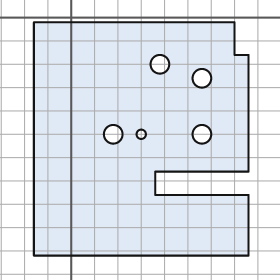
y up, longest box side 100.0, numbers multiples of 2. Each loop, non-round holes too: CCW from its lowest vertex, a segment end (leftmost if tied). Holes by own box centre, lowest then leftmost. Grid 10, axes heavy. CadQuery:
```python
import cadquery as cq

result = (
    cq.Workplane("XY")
    .moveTo(-16.0, -102.0)
    .lineTo(76.0, -102.0)
    .lineTo(76.0, -76.0)
    .lineTo(36.0, -76.0)
    .lineTo(36.0, -66.0)
    .lineTo(76.0, -66.0)
    .lineTo(76.0, -16.0)
    .lineTo(70.0, -16.0)
    .lineTo(70.0, -2.0)
    .lineTo(-16.0, -2.0)
    .close()
    .moveTo(18.0, -50.0)
    .circle(4.0)
    .moveTo(30.0, -50.0)
    .circle(2.0)
    .moveTo(56.0, -50.0)
    .circle(4.0)
    .moveTo(56.0, -26.0)
    .circle(4.0)
    .moveTo(38.0, -20.0)
    .circle(4.0)
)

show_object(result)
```